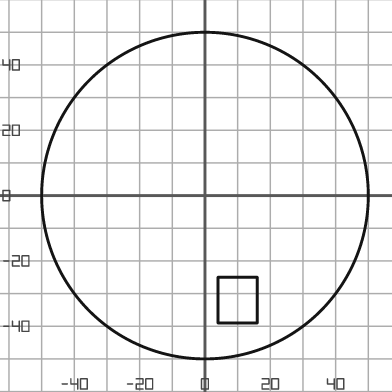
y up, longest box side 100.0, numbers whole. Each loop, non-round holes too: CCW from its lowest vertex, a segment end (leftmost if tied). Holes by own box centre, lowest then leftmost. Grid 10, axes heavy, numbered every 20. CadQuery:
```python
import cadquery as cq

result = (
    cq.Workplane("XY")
    .moveTo(0.0, 0.0)
    .circle(50.0)
    .moveTo(4.0, -39.0)
    .lineTo(16.0, -39.0)
    .lineTo(16.0, -25.0)
    .lineTo(4.0, -25.0)
    .close()
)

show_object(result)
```